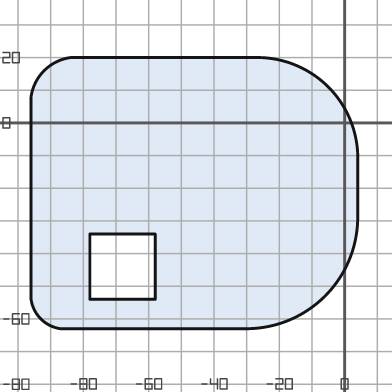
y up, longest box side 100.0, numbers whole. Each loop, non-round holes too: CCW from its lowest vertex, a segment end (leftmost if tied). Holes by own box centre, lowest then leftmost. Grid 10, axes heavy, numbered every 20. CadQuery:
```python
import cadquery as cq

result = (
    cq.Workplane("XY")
    .moveTo(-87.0, -63.0)
    .lineTo(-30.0, -63.0)
    .threePointArc((-6.0, -53.0), (4.0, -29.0))
    .lineTo(4.0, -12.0)
    .threePointArc((-5.0, 11.0), (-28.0, 20.0))
    .lineTo(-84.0, 20.0)
    .threePointArc((-92.0, 16.0), (-96.0, 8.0))
    .lineTo(-96.0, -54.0)
    .threePointArc((-93.0, -60.0), (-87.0, -63.0))
    .close()
    .moveTo(-78.0, -54.0)
    .lineTo(-58.0, -54.0)
    .lineTo(-58.0, -34.0)
    .lineTo(-78.0, -34.0)
    .close()
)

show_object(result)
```